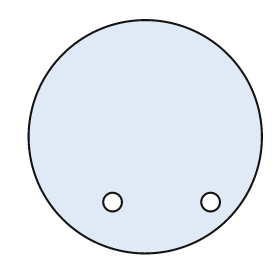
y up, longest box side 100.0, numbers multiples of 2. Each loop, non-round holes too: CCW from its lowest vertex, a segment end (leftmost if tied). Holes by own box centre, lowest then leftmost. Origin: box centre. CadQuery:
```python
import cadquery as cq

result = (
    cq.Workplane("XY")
    .moveTo(0.0, 0.0)
    .circle(50.0)
    .moveTo(-14.0, -28.0)
    .circle(4.0)
    .moveTo(28.0, -28.0)
    .circle(4.0)
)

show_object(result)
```